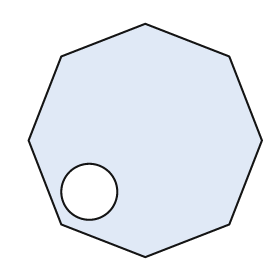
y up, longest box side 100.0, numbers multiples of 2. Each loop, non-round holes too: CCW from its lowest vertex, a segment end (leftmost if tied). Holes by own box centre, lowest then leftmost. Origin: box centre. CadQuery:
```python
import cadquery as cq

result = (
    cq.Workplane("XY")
    .moveTo(0.0, -50.0)
    .lineTo(36.0, -36.0)
    .lineTo(50.0, 0.0)
    .lineTo(36.0, 36.0)
    .lineTo(0.0, 50.0)
    .lineTo(-36.0, 36.0)
    .lineTo(-50.0, 0.0)
    .lineTo(-36.0, -36.0)
    .close()
    .moveTo(-24.0, -22.0)
    .circle(12.0)
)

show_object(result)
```